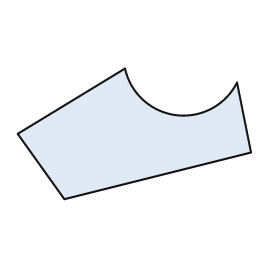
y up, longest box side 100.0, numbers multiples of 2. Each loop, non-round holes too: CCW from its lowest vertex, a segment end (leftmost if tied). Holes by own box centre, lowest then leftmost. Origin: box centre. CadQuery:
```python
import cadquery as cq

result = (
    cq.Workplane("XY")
    .moveTo(-30.0, -28.0)
    .lineTo(50.0, -8.0)
    .lineTo(44.0, 22.0)
    .threePointArc((18.0, 8.0), (-4.0, 28.0))
    .lineTo(-50.0, 0.0)
    .close()
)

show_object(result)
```